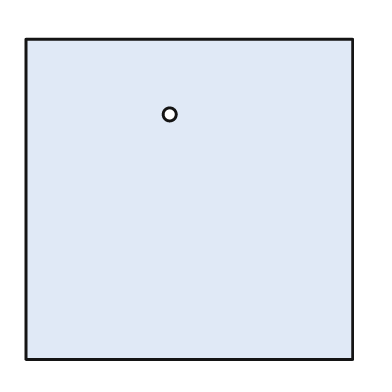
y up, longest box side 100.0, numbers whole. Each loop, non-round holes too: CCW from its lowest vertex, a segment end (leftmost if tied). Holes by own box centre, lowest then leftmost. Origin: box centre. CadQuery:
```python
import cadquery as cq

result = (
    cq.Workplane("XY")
    .moveTo(-50.0, -49.0)
    .lineTo(50.0, -49.0)
    .lineTo(50.0, 49.0)
    .lineTo(-50.0, 49.0)
    .close()
    .moveTo(-6.0, 26.0)
    .circle(2.0)
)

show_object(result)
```